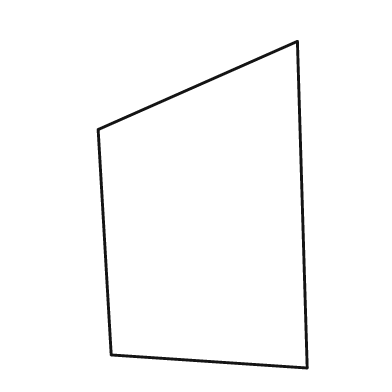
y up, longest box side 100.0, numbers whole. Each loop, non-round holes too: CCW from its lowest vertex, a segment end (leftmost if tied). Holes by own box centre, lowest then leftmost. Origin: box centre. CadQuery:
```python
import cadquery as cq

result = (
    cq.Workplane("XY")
    .moveTo(32.0, -50.0)
    .lineTo(29.0, 50.0)
    .lineTo(-32.0, 23.0)
    .lineTo(-28.0, -46.0)
    .close()
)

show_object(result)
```